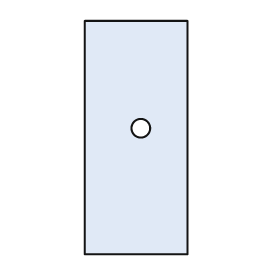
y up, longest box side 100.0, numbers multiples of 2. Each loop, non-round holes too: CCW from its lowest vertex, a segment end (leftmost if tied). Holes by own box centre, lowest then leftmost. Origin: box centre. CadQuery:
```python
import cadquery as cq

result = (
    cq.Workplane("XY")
    .moveTo(-22.0, -50.0)
    .lineTo(22.0, -50.0)
    .lineTo(22.0, 50.0)
    .lineTo(-22.0, 50.0)
    .close()
    .moveTo(2.0, 4.0)
    .circle(4.0)
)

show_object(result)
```